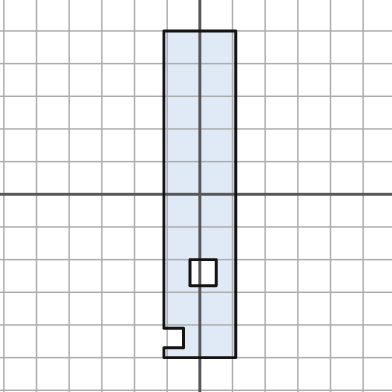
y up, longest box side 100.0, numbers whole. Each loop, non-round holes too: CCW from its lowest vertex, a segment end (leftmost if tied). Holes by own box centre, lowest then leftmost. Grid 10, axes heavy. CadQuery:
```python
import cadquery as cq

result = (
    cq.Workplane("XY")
    .moveTo(-11.0, -50.0)
    .lineTo(11.0, -50.0)
    .lineTo(11.0, 50.0)
    .lineTo(-11.0, 50.0)
    .lineTo(-11.0, -41.0)
    .lineTo(-5.0, -41.0)
    .lineTo(-5.0, -47.0)
    .lineTo(-11.0, -47.0)
    .close()
    .moveTo(-3.0, -28.0)
    .lineTo(5.0, -28.0)
    .lineTo(5.0, -20.0)
    .lineTo(-3.0, -20.0)
    .close()
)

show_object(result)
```